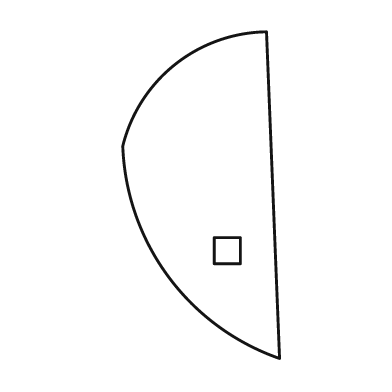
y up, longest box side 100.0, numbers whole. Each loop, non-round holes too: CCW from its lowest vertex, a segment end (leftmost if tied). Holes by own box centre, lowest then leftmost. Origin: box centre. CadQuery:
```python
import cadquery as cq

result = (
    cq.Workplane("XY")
    .moveTo(24.0, -50.0)
    .lineTo(20.0, 50.0)
    .threePointArc((-8.0, 40.0), (-24.0, 15.0))
    .threePointArc((-10.0, -25.0), (24.0, -50.0))
    .close()
    .moveTo(4.0, -21.0)
    .lineTo(12.0, -21.0)
    .lineTo(12.0, -13.0)
    .lineTo(4.0, -13.0)
    .close()
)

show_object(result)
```